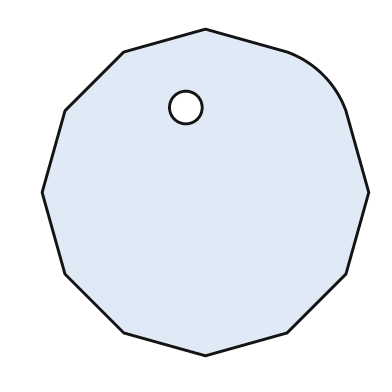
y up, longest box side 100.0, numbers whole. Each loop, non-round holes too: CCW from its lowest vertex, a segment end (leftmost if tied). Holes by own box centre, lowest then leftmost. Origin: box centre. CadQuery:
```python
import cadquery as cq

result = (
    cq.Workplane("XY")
    .moveTo(0.0, -50.0)
    .lineTo(25.0, -43.0)
    .lineTo(43.0, -25.0)
    .lineTo(50.0, 0.0)
    .lineTo(43.0, 25.0)
    .threePointArc((36.0, 36.0), (25.0, 43.0))
    .lineTo(0.0, 50.0)
    .lineTo(-25.0, 43.0)
    .lineTo(-43.0, 25.0)
    .lineTo(-50.0, 0.0)
    .lineTo(-43.0, -25.0)
    .lineTo(-25.0, -43.0)
    .close()
    .moveTo(-6.0, 26.0)
    .circle(5.0)
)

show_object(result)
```